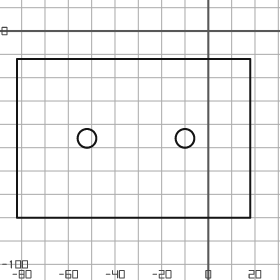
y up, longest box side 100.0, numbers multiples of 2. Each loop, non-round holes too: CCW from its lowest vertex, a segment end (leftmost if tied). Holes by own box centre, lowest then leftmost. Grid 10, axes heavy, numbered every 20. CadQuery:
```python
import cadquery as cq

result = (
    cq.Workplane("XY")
    .moveTo(-82.0, -80.0)
    .lineTo(18.0, -80.0)
    .lineTo(18.0, -12.0)
    .lineTo(-82.0, -12.0)
    .close()
    .moveTo(-52.0, -46.0)
    .circle(4.0)
    .moveTo(-10.0, -46.0)
    .circle(4.0)
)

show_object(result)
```